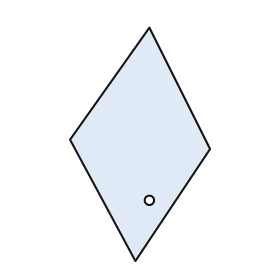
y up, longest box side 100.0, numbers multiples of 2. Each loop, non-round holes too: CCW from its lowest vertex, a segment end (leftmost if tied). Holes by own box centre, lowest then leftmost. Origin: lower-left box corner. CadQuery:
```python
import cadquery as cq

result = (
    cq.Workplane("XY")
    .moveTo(28.0, 0.0)
    .lineTo(60.0, 48.0)
    .lineTo(34.0, 100.0)
    .lineTo(0.0, 52.0)
    .close()
    .moveTo(34.0, 26.0)
    .circle(2.0)
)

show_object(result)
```